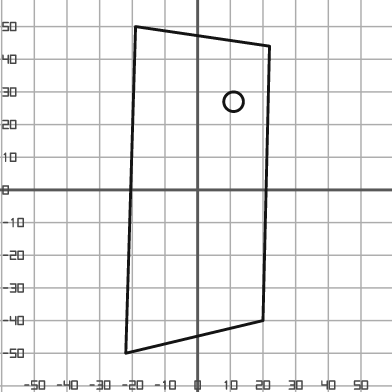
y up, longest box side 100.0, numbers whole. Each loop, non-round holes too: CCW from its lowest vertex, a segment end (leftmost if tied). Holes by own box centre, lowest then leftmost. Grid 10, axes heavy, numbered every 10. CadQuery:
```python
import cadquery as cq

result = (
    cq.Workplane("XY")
    .moveTo(-22.0, -50.0)
    .lineTo(20.0, -40.0)
    .lineTo(22.0, 44.0)
    .lineTo(-19.0, 50.0)
    .close()
    .moveTo(11.0, 27.0)
    .circle(3.0)
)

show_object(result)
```